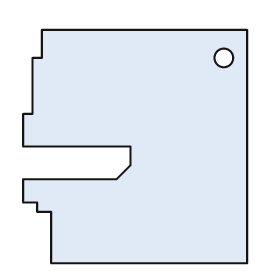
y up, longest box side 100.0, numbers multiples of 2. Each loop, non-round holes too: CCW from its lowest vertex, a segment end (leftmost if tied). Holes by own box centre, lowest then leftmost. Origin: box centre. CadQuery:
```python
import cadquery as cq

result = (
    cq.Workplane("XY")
    .moveTo(-36.0, -50.0)
    .lineTo(48.0, -50.0)
    .lineTo(48.0, 50.0)
    .lineTo(-40.0, 50.0)
    .lineTo(-40.0, 38.0)
    .lineTo(-44.0, 38.0)
    .lineTo(-44.0, 14.0)
    .lineTo(-48.0, 14.0)
    .lineTo(-48.0, 0.0)
    .lineTo(-2.0, 0.0)
    .lineTo(-2.0, -8.0)
    .lineTo(-8.0, -14.0)
    .lineTo(-48.0, -14.0)
    .lineTo(-48.0, -24.0)
    .lineTo(-42.0, -24.0)
    .lineTo(-42.0, -28.0)
    .lineTo(-36.0, -28.0)
    .close()
    .moveTo(38.0, 38.0)
    .circle(4.0)
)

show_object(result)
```